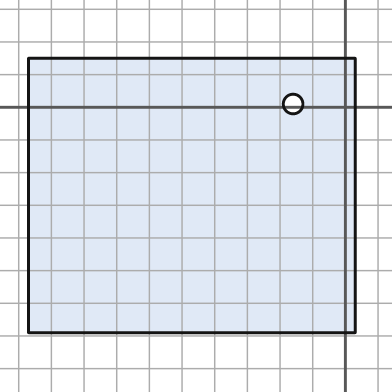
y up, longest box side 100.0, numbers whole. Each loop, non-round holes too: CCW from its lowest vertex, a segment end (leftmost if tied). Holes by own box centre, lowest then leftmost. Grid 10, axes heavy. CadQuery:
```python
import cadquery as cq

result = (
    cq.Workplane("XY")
    .moveTo(-97.0, -69.0)
    .lineTo(3.0, -69.0)
    .lineTo(3.0, 15.0)
    .lineTo(-97.0, 15.0)
    .close()
    .moveTo(-16.0, 1.0)
    .circle(3.0)
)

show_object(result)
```